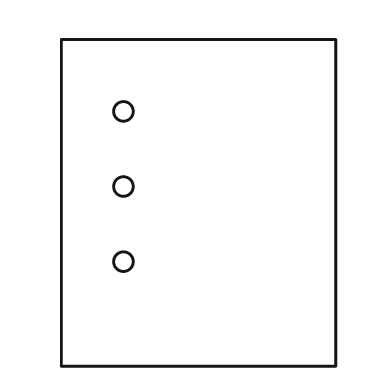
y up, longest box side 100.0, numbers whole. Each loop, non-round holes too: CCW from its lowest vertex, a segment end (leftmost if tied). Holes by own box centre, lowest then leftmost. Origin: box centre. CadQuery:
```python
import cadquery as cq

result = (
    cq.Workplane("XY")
    .moveTo(-42.0, -50.0)
    .lineTo(42.0, -50.0)
    .lineTo(42.0, 50.0)
    .lineTo(-42.0, 50.0)
    .close()
    .moveTo(-23.0, -18.0)
    .circle(3.0)
    .moveTo(-23.0, 5.0)
    .circle(3.0)
    .moveTo(-23.0, 28.0)
    .circle(3.0)
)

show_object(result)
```